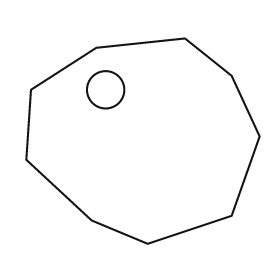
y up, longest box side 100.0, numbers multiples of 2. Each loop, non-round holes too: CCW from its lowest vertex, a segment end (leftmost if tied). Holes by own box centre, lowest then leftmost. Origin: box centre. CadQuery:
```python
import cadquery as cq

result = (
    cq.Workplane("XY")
    .moveTo(2.0, -44.0)
    .lineTo(38.0, -32.0)
    .lineTo(50.0, 2.0)
    .lineTo(38.0, 28.0)
    .lineTo(18.0, 44.0)
    .lineTo(-20.0, 40.0)
    .lineTo(-48.0, 22.0)
    .lineTo(-50.0, -8.0)
    .lineTo(-22.0, -34.0)
    .close()
    .moveTo(-16.0, 22.0)
    .circle(8.0)
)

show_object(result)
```